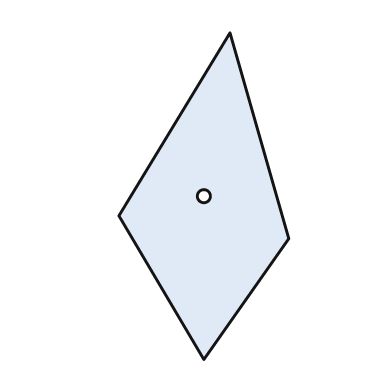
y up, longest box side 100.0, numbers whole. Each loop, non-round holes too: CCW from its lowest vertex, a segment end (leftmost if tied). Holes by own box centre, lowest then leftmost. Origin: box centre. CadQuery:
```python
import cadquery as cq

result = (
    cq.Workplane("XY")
    .moveTo(0.0, -50.0)
    .lineTo(26.0, -13.0)
    .lineTo(8.0, 50.0)
    .lineTo(-26.0, -6.0)
    .close()
    .moveTo(0.0, 0.0)
    .circle(2.0)
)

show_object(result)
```